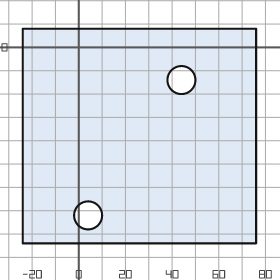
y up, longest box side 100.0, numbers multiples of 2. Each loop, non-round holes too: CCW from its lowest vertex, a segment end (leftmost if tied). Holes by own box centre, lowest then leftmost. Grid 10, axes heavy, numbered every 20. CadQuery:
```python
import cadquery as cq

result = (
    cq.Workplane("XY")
    .moveTo(-24.0, -84.0)
    .lineTo(76.0, -84.0)
    .lineTo(76.0, 8.0)
    .lineTo(-24.0, 8.0)
    .close()
    .moveTo(4.0, -72.0)
    .circle(6.0)
    .moveTo(44.0, -14.0)
    .circle(6.0)
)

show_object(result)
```